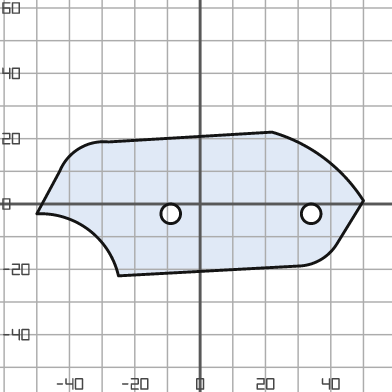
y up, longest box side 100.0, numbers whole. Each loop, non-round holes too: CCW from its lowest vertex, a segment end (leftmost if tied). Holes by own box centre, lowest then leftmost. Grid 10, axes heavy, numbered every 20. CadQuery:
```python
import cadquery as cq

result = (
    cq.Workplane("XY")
    .moveTo(-25.0, -22.0)
    .lineTo(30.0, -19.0)
    .threePointArc((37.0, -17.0), (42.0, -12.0))
    .lineTo(50.0, 1.0)
    .threePointArc((38.0, 14.0), (22.0, 22.0))
    .lineTo(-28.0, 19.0)
    .threePointArc((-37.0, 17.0), (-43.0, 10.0))
    .lineTo(-50.0, -3.0)
    .threePointArc((-34.0, -8.0), (-25.0, -22.0))
    .close()
    .moveTo(-9.0, -3.0)
    .circle(3.0)
    .moveTo(34.0, -3.0)
    .circle(3.0)
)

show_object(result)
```